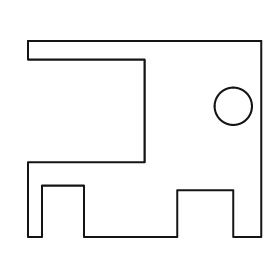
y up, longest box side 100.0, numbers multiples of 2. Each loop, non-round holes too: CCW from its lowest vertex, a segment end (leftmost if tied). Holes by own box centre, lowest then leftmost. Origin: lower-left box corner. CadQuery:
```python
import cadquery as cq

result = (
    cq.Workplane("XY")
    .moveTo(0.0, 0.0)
    .lineTo(6.0, 0.0)
    .lineTo(6.0, 22.0)
    .lineTo(24.0, 22.0)
    .lineTo(24.0, 0.0)
    .lineTo(64.0, 0.0)
    .lineTo(64.0, 20.0)
    .lineTo(88.0, 20.0)
    .lineTo(88.0, 0.0)
    .lineTo(100.0, 0.0)
    .lineTo(100.0, 84.0)
    .lineTo(0.0, 84.0)
    .lineTo(0.0, 76.0)
    .lineTo(50.0, 76.0)
    .lineTo(50.0, 32.0)
    .lineTo(0.0, 32.0)
    .close()
    .moveTo(88.0, 56.0)
    .circle(8.0)
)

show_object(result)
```